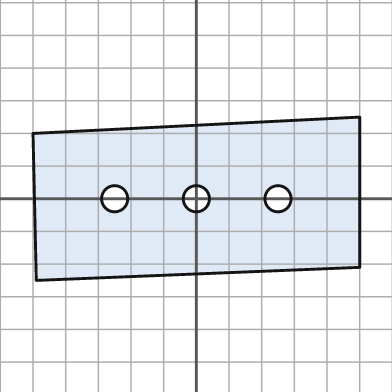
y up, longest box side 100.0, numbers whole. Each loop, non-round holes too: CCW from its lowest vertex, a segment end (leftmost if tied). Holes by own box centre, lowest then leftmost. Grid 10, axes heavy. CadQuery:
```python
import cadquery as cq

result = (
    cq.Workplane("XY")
    .moveTo(-49.0, -25.0)
    .lineTo(50.0, -21.0)
    .lineTo(50.0, 25.0)
    .lineTo(-50.0, 20.0)
    .close()
    .moveTo(-25.0, 0.0)
    .circle(4.0)
    .moveTo(0.0, 0.0)
    .circle(4.0)
    .moveTo(25.0, 0.0)
    .circle(4.0)
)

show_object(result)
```